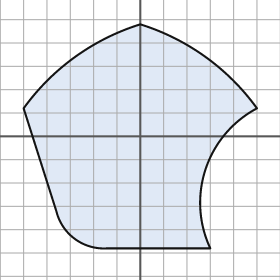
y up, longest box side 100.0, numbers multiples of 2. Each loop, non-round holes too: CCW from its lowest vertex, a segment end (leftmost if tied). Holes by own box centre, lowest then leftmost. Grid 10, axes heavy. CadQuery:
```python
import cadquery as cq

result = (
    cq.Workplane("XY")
    .moveTo(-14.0, -48.0)
    .lineTo(30.0, -48.0)
    .threePointArc((28.0, -14.0), (50.0, 12.0))
    .threePointArc((28.0, 34.0), (0.0, 48.0))
    .threePointArc((-28.0, 34.0), (-50.0, 12.0))
    .lineTo(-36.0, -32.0)
    .threePointArc((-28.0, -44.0), (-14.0, -48.0))
    .close()
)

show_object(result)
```